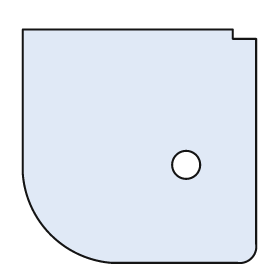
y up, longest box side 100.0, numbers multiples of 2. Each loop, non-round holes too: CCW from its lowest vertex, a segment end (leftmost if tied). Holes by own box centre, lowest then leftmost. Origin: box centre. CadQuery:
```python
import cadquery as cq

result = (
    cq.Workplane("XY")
    .moveTo(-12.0, -50.0)
    .lineTo(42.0, -50.0)
    .threePointArc((48.0, -48.0), (50.0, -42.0))
    .lineTo(50.0, 46.0)
    .lineTo(40.0, 46.0)
    .lineTo(40.0, 50.0)
    .lineTo(-50.0, 50.0)
    .lineTo(-50.0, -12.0)
    .threePointArc((-38.0, -38.0), (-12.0, -50.0))
    .close()
    .moveTo(20.0, -8.0)
    .circle(6.0)
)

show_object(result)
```